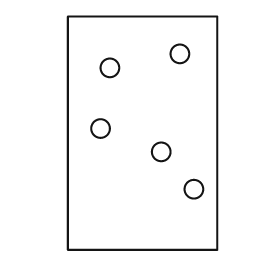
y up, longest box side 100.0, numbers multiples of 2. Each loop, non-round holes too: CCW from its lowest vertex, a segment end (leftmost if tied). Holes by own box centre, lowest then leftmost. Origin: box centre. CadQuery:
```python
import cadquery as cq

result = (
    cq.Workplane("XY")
    .moveTo(-32.0, -50.0)
    .lineTo(32.0, -50.0)
    .lineTo(32.0, 50.0)
    .lineTo(-32.0, 50.0)
    .close()
    .moveTo(22.0, -24.0)
    .circle(4.0)
    .moveTo(8.0, -8.0)
    .circle(4.0)
    .moveTo(-18.0, 2.0)
    .circle(4.0)
    .moveTo(-14.0, 28.0)
    .circle(4.0)
    .moveTo(16.0, 34.0)
    .circle(4.0)
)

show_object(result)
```